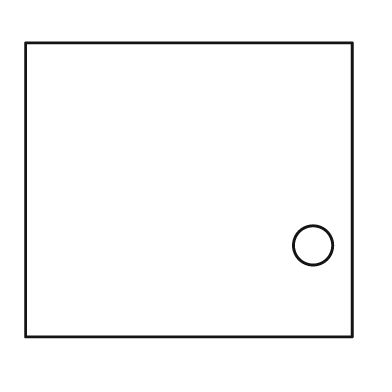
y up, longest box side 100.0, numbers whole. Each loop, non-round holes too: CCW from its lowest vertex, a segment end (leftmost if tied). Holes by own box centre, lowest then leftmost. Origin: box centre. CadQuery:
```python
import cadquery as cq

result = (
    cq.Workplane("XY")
    .moveTo(-50.0, -45.0)
    .lineTo(50.0, -45.0)
    .lineTo(50.0, 45.0)
    .lineTo(-50.0, 45.0)
    .close()
    .moveTo(38.0, -17.0)
    .circle(6.0)
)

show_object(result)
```